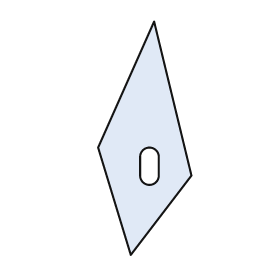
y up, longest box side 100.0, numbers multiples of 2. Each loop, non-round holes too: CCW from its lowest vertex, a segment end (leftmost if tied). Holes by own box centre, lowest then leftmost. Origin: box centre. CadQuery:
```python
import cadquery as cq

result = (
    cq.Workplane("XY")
    .moveTo(-6.0, -50.0)
    .lineTo(20.0, -16.0)
    .lineTo(4.0, 50.0)
    .lineTo(-20.0, -4.0)
    .close()
    .moveTo(-2.0, -16.0)
    .threePointArc((2.0, -20.0), (6.0, -16.0))
    .lineTo(6.0, -8.0)
    .threePointArc((2.0, -4.0), (-2.0, -8.0))
    .close()
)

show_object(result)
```